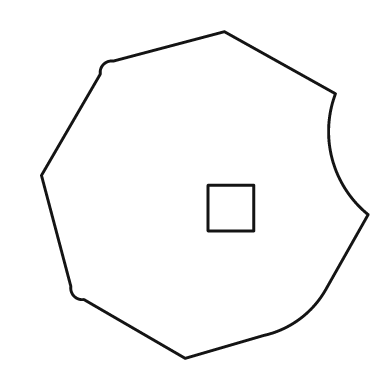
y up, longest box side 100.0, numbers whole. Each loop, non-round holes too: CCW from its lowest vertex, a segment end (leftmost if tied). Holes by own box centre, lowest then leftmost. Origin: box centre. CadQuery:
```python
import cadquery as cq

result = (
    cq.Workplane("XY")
    .moveTo(-6.0, -50.0)
    .lineTo(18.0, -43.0)
    .threePointArc((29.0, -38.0), (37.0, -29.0))
    .lineTo(50.0, -6.0)
    .threePointArc((39.0, 11.0), (40.0, 31.0))
    .lineTo(6.0, 50.0)
    .lineTo(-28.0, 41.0)
    .threePointArc((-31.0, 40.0), (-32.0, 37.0))
    .lineTo(-50.0, 6.0)
    .lineTo(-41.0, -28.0)
    .threePointArc((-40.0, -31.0), (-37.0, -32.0))
    .close()
    .moveTo(1.0, -11.0)
    .lineTo(15.0, -11.0)
    .lineTo(15.0, 3.0)
    .lineTo(1.0, 3.0)
    .close()
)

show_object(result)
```